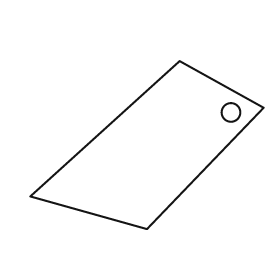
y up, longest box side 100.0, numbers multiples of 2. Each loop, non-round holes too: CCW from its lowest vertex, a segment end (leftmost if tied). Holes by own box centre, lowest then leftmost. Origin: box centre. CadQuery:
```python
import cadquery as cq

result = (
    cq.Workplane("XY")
    .moveTo(0.0, -36.0)
    .lineTo(50.0, 16.0)
    .lineTo(14.0, 36.0)
    .lineTo(-50.0, -22.0)
    .close()
    .moveTo(36.0, 14.0)
    .circle(4.0)
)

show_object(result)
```